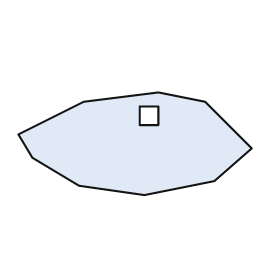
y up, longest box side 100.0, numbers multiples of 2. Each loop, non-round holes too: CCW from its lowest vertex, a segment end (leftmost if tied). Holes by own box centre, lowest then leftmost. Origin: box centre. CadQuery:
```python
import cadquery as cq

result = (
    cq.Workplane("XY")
    .moveTo(4.0, -22.0)
    .lineTo(34.0, -16.0)
    .lineTo(50.0, -2.0)
    .lineTo(30.0, 18.0)
    .lineTo(10.0, 22.0)
    .lineTo(-22.0, 18.0)
    .lineTo(-50.0, 4.0)
    .lineTo(-44.0, -6.0)
    .lineTo(-24.0, -18.0)
    .close()
    .moveTo(2.0, 8.0)
    .lineTo(10.0, 8.0)
    .lineTo(10.0, 16.0)
    .lineTo(2.0, 16.0)
    .close()
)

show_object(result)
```